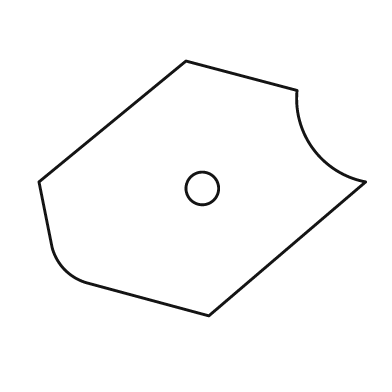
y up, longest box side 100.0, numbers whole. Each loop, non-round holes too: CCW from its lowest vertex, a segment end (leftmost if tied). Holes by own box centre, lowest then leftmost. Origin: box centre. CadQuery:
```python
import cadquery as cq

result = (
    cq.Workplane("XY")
    .moveTo(2.0, -39.0)
    .lineTo(50.0, 2.0)
    .threePointArc((34.0, 12.0), (29.0, 30.0))
    .lineTo(-5.0, 39.0)
    .lineTo(-50.0, 2.0)
    .lineTo(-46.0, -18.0)
    .threePointArc((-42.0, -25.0), (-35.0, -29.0))
    .close()
    .moveTo(0.0, 0.0)
    .circle(5.0)
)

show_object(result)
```